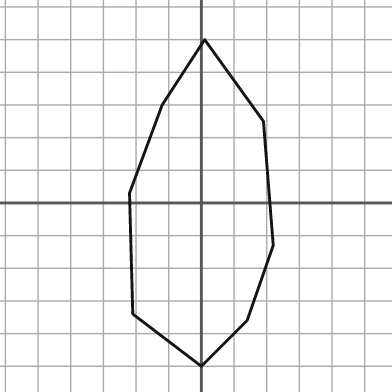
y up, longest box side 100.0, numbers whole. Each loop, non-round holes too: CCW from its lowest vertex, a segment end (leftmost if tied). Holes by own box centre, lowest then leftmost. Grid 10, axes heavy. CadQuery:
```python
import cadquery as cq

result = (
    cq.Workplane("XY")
    .moveTo(0.0, -50.0)
    .lineTo(14.0, -36.0)
    .lineTo(22.0, -13.0)
    .lineTo(19.0, 25.0)
    .lineTo(1.0, 50.0)
    .lineTo(-12.0, 30.0)
    .lineTo(-22.0, 3.0)
    .lineTo(-21.0, -34.0)
    .close()
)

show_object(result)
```